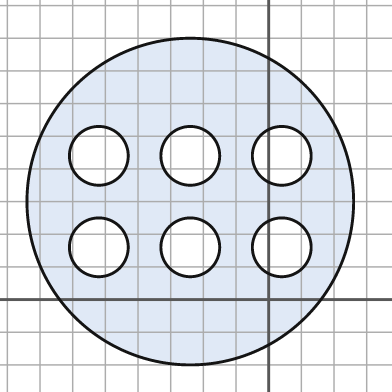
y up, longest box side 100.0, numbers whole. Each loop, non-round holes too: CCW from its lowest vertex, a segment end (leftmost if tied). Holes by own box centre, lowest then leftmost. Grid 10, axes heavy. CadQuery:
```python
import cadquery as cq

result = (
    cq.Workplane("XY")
    .moveTo(-24.0, 30.0)
    .circle(50.0)
    .moveTo(-52.0, 16.0)
    .circle(9.0)
    .moveTo(-24.0, 16.0)
    .circle(9.0)
    .moveTo(4.0, 16.0)
    .circle(9.0)
    .moveTo(-52.0, 44.0)
    .circle(9.0)
    .moveTo(-24.0, 44.0)
    .circle(9.0)
    .moveTo(4.0, 44.0)
    .circle(9.0)
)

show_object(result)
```